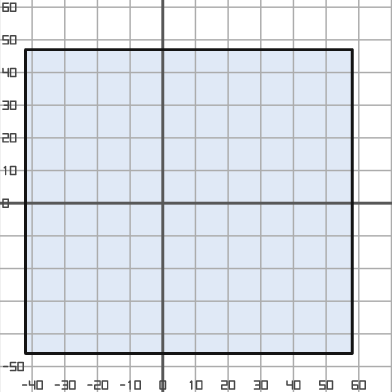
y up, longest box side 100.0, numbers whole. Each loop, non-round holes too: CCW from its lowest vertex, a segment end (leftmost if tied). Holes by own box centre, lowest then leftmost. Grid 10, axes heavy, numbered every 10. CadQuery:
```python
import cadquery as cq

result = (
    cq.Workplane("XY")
    .moveTo(-42.0, -46.0)
    .lineTo(58.0, -46.0)
    .lineTo(58.0, 47.0)
    .lineTo(-42.0, 47.0)
    .close()
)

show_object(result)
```